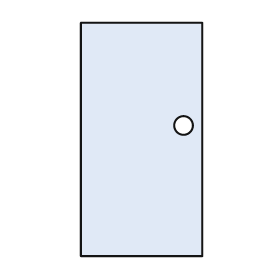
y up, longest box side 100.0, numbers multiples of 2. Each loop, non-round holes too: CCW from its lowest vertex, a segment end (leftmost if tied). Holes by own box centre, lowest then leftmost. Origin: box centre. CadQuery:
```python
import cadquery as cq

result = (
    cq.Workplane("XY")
    .moveTo(-26.0, -50.0)
    .lineTo(26.0, -50.0)
    .lineTo(26.0, 50.0)
    .lineTo(-26.0, 50.0)
    .close()
    .moveTo(18.0, 6.0)
    .circle(4.0)
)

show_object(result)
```